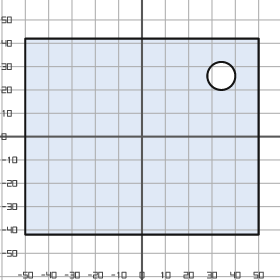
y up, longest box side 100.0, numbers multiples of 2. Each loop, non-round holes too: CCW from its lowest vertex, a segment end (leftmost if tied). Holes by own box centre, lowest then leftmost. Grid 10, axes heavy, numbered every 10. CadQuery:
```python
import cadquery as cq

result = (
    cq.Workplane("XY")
    .moveTo(-50.0, -42.0)
    .lineTo(50.0, -42.0)
    .lineTo(50.0, 42.0)
    .lineTo(-50.0, 42.0)
    .close()
    .moveTo(34.0, 26.0)
    .circle(6.0)
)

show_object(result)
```